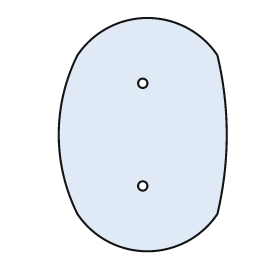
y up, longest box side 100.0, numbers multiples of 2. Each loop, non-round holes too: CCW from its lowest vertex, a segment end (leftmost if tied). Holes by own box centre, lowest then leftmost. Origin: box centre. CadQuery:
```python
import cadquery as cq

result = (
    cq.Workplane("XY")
    .moveTo(-28.0, -34.0)
    .threePointArc((2.0, -50.0), (32.0, -34.0))
    .threePointArc((36.0, 0.0), (32.0, 34.0))
    .threePointArc((2.0, 50.0), (-28.0, 34.0))
    .threePointArc((-36.0, 0.0), (-28.0, -34.0))
    .close()
    .moveTo(0.0, -22.0)
    .circle(2.0)
    .moveTo(0.0, 22.0)
    .circle(2.0)
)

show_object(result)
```